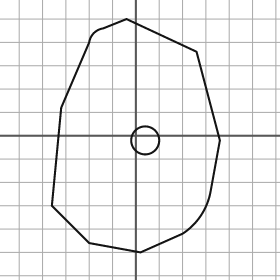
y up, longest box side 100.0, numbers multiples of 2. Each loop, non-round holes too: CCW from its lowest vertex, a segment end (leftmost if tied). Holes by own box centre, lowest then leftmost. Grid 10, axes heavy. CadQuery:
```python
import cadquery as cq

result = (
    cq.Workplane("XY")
    .moveTo(2.0, -50.0)
    .lineTo(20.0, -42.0)
    .threePointArc((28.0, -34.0), (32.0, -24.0))
    .lineTo(36.0, -2.0)
    .lineTo(26.0, 36.0)
    .lineTo(-4.0, 50.0)
    .lineTo(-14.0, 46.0)
    .threePointArc((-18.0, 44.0), (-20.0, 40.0))
    .lineTo(-32.0, 12.0)
    .lineTo(-36.0, -30.0)
    .lineTo(-20.0, -46.0)
    .close()
    .moveTo(4.0, -2.0)
    .circle(6.0)
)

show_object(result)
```